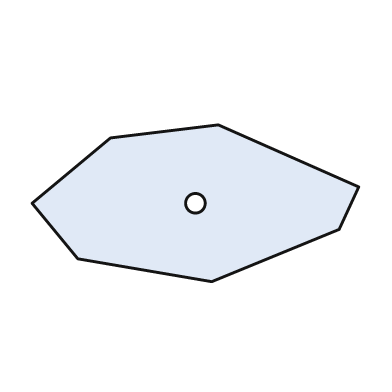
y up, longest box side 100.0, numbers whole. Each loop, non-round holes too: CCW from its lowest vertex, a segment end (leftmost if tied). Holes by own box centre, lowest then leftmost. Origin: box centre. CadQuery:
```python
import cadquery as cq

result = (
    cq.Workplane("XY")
    .moveTo(5.0, -24.0)
    .lineTo(44.0, -8.0)
    .lineTo(50.0, 5.0)
    .lineTo(7.0, 24.0)
    .lineTo(-26.0, 20.0)
    .lineTo(-50.0, 0.0)
    .lineTo(-36.0, -17.0)
    .close()
    .moveTo(0.0, 0.0)
    .circle(3.0)
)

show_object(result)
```